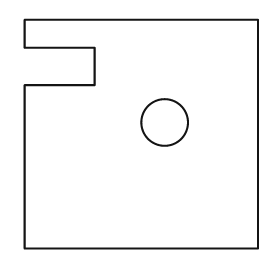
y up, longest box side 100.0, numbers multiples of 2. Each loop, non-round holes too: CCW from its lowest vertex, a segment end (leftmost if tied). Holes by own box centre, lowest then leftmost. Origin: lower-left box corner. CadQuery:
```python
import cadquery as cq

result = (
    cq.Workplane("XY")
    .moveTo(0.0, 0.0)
    .lineTo(100.0, 0.0)
    .lineTo(100.0, 98.0)
    .lineTo(0.0, 98.0)
    .lineTo(0.0, 86.0)
    .lineTo(30.0, 86.0)
    .lineTo(30.0, 70.0)
    .lineTo(0.0, 70.0)
    .close()
    .moveTo(60.0, 54.0)
    .circle(10.0)
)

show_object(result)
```